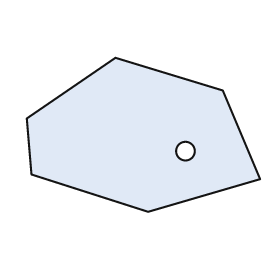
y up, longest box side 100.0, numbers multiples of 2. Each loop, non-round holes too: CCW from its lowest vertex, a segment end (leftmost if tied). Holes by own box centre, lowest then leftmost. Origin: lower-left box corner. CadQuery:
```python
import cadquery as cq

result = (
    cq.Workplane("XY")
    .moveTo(52.0, 0.0)
    .lineTo(100.0, 14.0)
    .lineTo(84.0, 52.0)
    .lineTo(38.0, 66.0)
    .lineTo(0.0, 40.0)
    .lineTo(2.0, 16.0)
    .close()
    .moveTo(68.0, 26.0)
    .circle(4.0)
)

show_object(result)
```